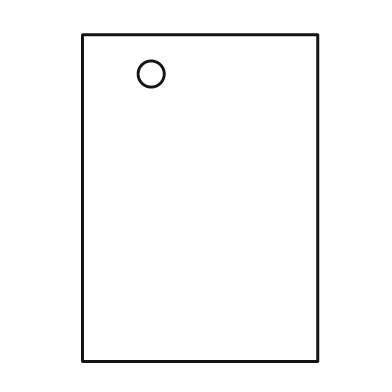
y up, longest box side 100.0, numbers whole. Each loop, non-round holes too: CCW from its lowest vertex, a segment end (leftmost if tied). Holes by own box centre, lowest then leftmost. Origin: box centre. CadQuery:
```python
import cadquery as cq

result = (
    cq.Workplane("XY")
    .moveTo(-36.0, -50.0)
    .lineTo(36.0, -50.0)
    .lineTo(36.0, 50.0)
    .lineTo(-36.0, 50.0)
    .close()
    .moveTo(-15.0, 38.0)
    .circle(4.0)
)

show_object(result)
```